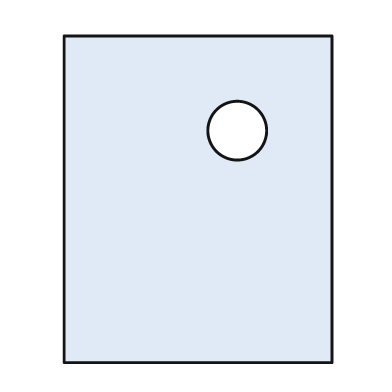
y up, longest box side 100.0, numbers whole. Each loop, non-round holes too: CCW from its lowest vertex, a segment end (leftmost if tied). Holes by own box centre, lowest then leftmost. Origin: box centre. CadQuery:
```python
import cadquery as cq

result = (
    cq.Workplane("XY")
    .moveTo(-41.0, -50.0)
    .lineTo(41.0, -50.0)
    .lineTo(41.0, 50.0)
    .lineTo(-41.0, 50.0)
    .close()
    .moveTo(12.0, 21.0)
    .circle(9.0)
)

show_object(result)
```